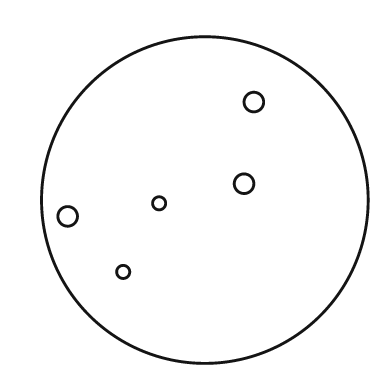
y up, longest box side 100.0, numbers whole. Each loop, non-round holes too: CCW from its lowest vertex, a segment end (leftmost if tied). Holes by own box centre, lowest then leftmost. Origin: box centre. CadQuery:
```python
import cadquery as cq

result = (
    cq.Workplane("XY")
    .moveTo(0.0, 0.0)
    .circle(50.0)
    .moveTo(-25.0, -22.0)
    .circle(2.0)
    .moveTo(-42.0, -5.0)
    .circle(3.0)
    .moveTo(-14.0, -1.0)
    .circle(2.0)
    .moveTo(12.0, 5.0)
    .circle(3.0)
    .moveTo(15.0, 30.0)
    .circle(3.0)
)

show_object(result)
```